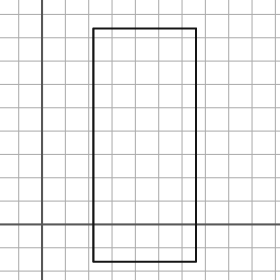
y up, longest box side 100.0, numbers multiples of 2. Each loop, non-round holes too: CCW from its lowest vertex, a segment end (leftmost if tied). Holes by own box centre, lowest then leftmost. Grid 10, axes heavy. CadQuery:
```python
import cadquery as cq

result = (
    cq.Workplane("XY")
    .moveTo(22.0, -16.0)
    .lineTo(66.0, -16.0)
    .lineTo(66.0, 84.0)
    .lineTo(22.0, 84.0)
    .close()
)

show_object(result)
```